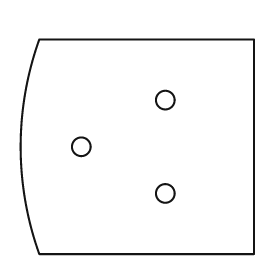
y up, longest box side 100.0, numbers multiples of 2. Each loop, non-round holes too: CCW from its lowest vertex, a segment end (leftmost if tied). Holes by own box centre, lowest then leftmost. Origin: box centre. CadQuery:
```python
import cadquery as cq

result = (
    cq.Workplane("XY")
    .moveTo(-42.0, -46.0)
    .lineTo(50.0, -46.0)
    .lineTo(50.0, 46.0)
    .lineTo(-42.0, 46.0)
    .threePointArc((-50.0, 0.0), (-42.0, -46.0))
    .close()
    .moveTo(12.0, -20.0)
    .circle(4.0)
    .moveTo(-24.0, 0.0)
    .circle(4.0)
    .moveTo(12.0, 20.0)
    .circle(4.0)
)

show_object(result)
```